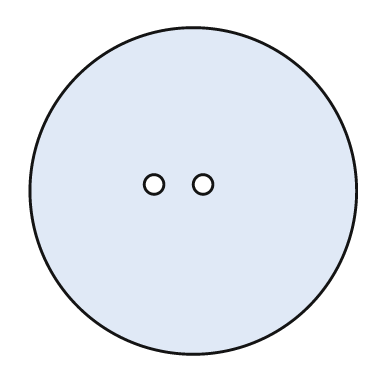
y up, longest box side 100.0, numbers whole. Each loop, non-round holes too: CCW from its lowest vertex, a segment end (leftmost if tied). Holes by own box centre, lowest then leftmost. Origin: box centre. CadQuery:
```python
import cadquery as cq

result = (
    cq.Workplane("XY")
    .moveTo(0.0, 0.0)
    .circle(50.0)
    .moveTo(-12.0, 2.0)
    .circle(3.0)
    .moveTo(3.0, 2.0)
    .circle(3.0)
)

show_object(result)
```